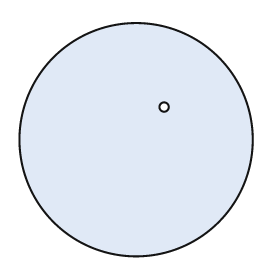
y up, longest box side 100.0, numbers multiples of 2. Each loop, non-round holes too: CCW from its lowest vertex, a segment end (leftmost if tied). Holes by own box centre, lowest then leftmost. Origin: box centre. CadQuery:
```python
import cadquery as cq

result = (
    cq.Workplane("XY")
    .moveTo(0.0, 0.0)
    .circle(50.0)
    .moveTo(12.0, 14.0)
    .circle(2.0)
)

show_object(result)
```